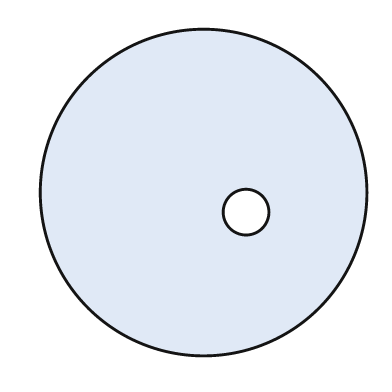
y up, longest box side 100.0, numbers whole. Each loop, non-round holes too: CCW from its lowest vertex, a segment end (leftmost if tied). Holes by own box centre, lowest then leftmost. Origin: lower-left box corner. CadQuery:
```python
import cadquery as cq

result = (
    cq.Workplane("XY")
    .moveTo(50.0, 50.0)
    .circle(50.0)
    .moveTo(63.0, 44.0)
    .circle(7.0)
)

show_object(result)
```